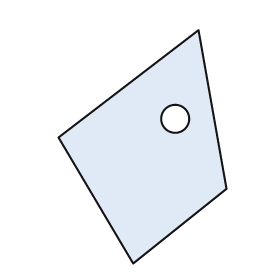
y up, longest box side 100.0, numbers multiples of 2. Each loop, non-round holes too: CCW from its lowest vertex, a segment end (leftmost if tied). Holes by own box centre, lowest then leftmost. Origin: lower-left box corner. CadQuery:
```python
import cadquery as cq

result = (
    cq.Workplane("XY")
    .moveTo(32.0, 0.0)
    .lineTo(72.0, 32.0)
    .lineTo(60.0, 100.0)
    .lineTo(0.0, 54.0)
    .close()
    .moveTo(50.0, 62.0)
    .circle(6.0)
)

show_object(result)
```